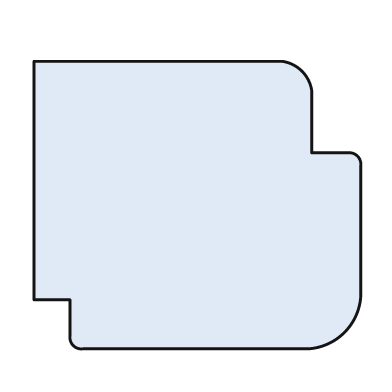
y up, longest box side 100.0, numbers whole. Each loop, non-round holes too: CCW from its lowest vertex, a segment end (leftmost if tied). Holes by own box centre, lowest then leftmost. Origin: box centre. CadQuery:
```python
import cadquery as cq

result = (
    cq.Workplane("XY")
    .moveTo(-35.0, -44.0)
    .lineTo(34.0, -44.0)
    .threePointArc((45.0, -39.0), (50.0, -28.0))
    .lineTo(50.0, 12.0)
    .threePointArc((49.0, 15.0), (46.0, 16.0))
    .lineTo(35.0, 16.0)
    .lineTo(35.0, 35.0)
    .threePointArc((32.0, 41.0), (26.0, 44.0))
    .lineTo(-50.0, 44.0)
    .lineTo(-50.0, -29.0)
    .lineTo(-39.0, -29.0)
    .lineTo(-39.0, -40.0)
    .threePointArc((-38.0, -43.0), (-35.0, -44.0))
    .close()
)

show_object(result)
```